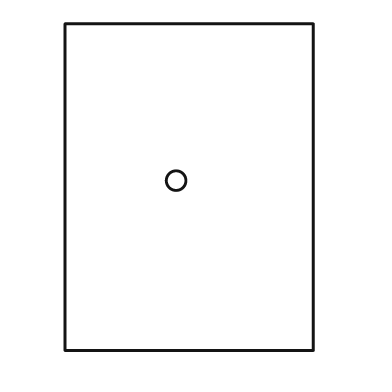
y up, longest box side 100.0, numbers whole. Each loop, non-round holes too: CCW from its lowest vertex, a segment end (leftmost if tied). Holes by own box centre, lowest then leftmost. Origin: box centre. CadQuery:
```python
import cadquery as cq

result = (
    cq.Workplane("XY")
    .moveTo(-38.0, -50.0)
    .lineTo(38.0, -50.0)
    .lineTo(38.0, 50.0)
    .lineTo(-38.0, 50.0)
    .close()
    .moveTo(-4.0, 2.0)
    .circle(3.0)
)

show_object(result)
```